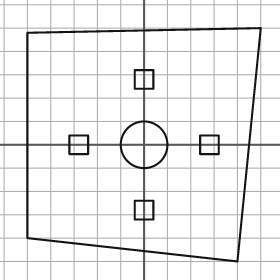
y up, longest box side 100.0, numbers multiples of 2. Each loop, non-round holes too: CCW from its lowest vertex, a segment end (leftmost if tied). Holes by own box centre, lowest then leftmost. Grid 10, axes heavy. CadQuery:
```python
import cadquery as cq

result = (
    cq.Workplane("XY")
    .moveTo(40.0, -50.0)
    .lineTo(50.0, 50.0)
    .lineTo(-50.0, 48.0)
    .lineTo(-50.0, -40.0)
    .close()
    .moveTo(-4.0, -32.0)
    .lineTo(4.0, -32.0)
    .lineTo(4.0, -24.0)
    .lineTo(-4.0, -24.0)
    .close()
    .moveTo(-32.0, -4.0)
    .lineTo(-24.0, -4.0)
    .lineTo(-24.0, 4.0)
    .lineTo(-32.0, 4.0)
    .close()
    .moveTo(0.0, 0.0)
    .circle(10.0)
    .moveTo(24.0, -4.0)
    .lineTo(32.0, -4.0)
    .lineTo(32.0, 4.0)
    .lineTo(24.0, 4.0)
    .close()
    .moveTo(-4.0, 24.0)
    .lineTo(4.0, 24.0)
    .lineTo(4.0, 32.0)
    .lineTo(-4.0, 32.0)
    .close()
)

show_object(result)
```